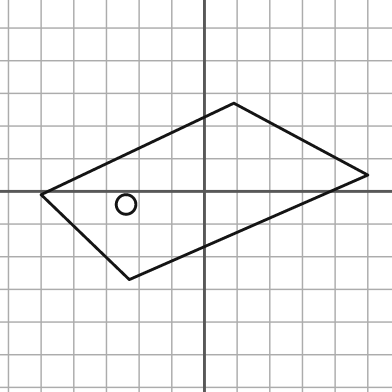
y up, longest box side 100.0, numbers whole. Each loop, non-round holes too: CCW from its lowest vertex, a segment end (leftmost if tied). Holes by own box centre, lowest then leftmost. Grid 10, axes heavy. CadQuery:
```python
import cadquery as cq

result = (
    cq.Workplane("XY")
    .moveTo(-23.0, -27.0)
    .lineTo(50.0, 5.0)
    .lineTo(9.0, 27.0)
    .lineTo(-50.0, -1.0)
    .close()
    .moveTo(-24.0, -4.0)
    .circle(3.0)
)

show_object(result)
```